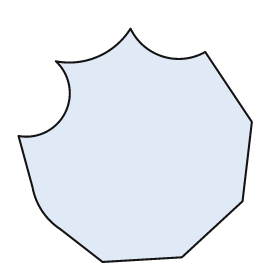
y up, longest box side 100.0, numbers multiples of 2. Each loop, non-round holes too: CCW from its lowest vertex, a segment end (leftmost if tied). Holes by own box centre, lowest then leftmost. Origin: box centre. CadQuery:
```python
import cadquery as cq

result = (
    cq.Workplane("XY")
    .moveTo(-14.0, -50.0)
    .lineTo(20.0, -48.0)
    .lineTo(46.0, -24.0)
    .lineTo(50.0, 10.0)
    .lineTo(30.0, 40.0)
    .threePointArc((12.0, 38.0), (-2.0, 50.0))
    .threePointArc((-16.0, 38.0), (-34.0, 36.0))
    .threePointArc((-30.0, 14.0), (-50.0, 4.0))
    .lineTo(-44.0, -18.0)
    .threePointArc((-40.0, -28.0), (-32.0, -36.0))
    .close()
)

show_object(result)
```